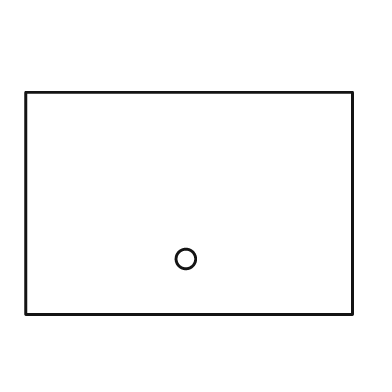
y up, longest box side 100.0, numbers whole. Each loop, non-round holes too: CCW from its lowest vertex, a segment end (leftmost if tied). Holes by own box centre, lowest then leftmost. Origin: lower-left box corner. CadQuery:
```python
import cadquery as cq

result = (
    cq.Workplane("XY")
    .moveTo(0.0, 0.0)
    .lineTo(100.0, 0.0)
    .lineTo(100.0, 68.0)
    .lineTo(0.0, 68.0)
    .close()
    .moveTo(49.0, 17.0)
    .circle(3.0)
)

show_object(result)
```